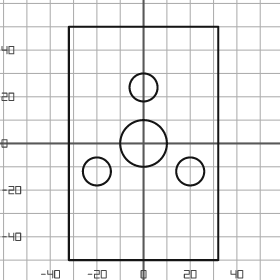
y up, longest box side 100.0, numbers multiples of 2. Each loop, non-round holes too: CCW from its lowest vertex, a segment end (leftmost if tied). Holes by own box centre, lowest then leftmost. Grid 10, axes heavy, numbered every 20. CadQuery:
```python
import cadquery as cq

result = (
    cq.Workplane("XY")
    .moveTo(-32.0, -50.0)
    .lineTo(32.0, -50.0)
    .lineTo(32.0, 50.0)
    .lineTo(-32.0, 50.0)
    .close()
    .moveTo(-20.0, -12.0)
    .circle(6.0)
    .moveTo(20.0, -12.0)
    .circle(6.0)
    .moveTo(0.0, 0.0)
    .circle(10.0)
    .moveTo(0.0, 24.0)
    .circle(6.0)
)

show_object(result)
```